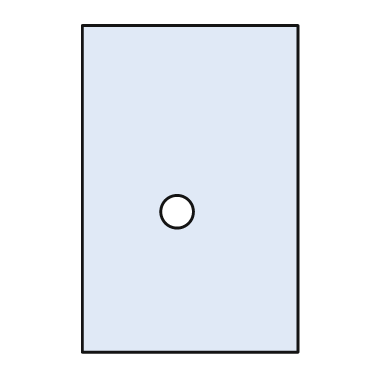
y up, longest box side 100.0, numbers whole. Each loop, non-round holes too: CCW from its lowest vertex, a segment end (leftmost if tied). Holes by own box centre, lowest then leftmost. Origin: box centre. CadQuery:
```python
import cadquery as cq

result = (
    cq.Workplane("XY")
    .moveTo(-33.0, -50.0)
    .lineTo(33.0, -50.0)
    .lineTo(33.0, 50.0)
    .lineTo(-33.0, 50.0)
    .close()
    .moveTo(-4.0, -7.0)
    .circle(5.0)
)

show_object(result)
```